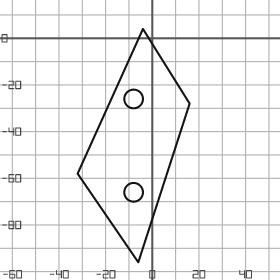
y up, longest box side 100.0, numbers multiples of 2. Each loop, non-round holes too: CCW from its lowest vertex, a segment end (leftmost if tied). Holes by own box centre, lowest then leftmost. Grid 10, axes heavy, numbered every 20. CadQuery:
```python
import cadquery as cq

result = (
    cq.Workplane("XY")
    .moveTo(-6.0, -96.0)
    .lineTo(16.0, -28.0)
    .lineTo(-4.0, 4.0)
    .lineTo(-32.0, -58.0)
    .close()
    .moveTo(-8.0, -66.0)
    .circle(4.0)
    .moveTo(-8.0, -26.0)
    .circle(4.0)
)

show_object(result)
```